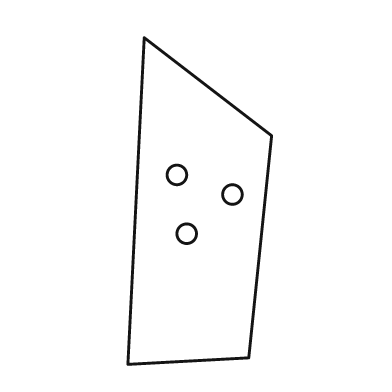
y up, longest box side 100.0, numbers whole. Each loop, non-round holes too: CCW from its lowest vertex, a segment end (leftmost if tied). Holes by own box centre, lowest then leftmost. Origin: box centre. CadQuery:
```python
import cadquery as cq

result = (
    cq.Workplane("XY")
    .moveTo(-22.0, -50.0)
    .lineTo(15.0, -48.0)
    .lineTo(22.0, 20.0)
    .lineTo(-17.0, 50.0)
    .close()
    .moveTo(-4.0, -10.0)
    .circle(3.0)
    .moveTo(10.0, 2.0)
    .circle(3.0)
    .moveTo(-7.0, 8.0)
    .circle(3.0)
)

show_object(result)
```